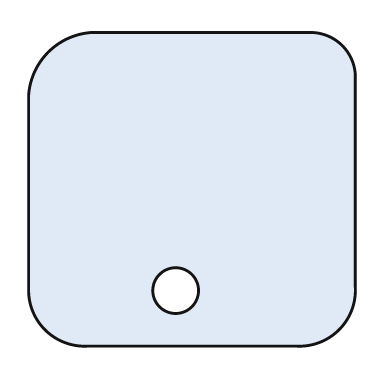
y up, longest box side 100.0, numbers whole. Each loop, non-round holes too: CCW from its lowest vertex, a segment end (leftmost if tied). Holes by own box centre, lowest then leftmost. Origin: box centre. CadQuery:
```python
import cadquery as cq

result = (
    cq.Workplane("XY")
    .moveTo(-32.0, -48.0)
    .lineTo(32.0, -48.0)
    .threePointArc((45.0, -43.0), (50.0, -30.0))
    .lineTo(50.0, 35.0)
    .threePointArc((46.0, 44.0), (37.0, 48.0))
    .lineTo(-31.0, 48.0)
    .threePointArc((-44.0, 42.0), (-50.0, 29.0))
    .lineTo(-50.0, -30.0)
    .threePointArc((-45.0, -43.0), (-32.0, -48.0))
    .close()
    .moveTo(-5.0, -31.0)
    .circle(7.0)
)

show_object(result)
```